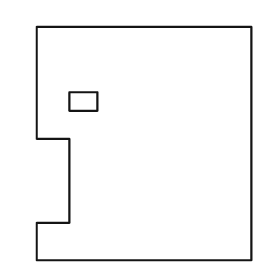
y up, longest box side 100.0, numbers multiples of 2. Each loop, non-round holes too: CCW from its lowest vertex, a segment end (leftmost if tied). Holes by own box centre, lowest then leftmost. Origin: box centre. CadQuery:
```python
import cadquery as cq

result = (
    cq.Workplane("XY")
    .moveTo(-46.0, -50.0)
    .lineTo(46.0, -50.0)
    .lineTo(46.0, 50.0)
    .lineTo(-46.0, 50.0)
    .lineTo(-46.0, 2.0)
    .lineTo(-32.0, 2.0)
    .lineTo(-32.0, -34.0)
    .lineTo(-46.0, -34.0)
    .close()
    .moveTo(-32.0, 14.0)
    .lineTo(-20.0, 14.0)
    .lineTo(-20.0, 22.0)
    .lineTo(-32.0, 22.0)
    .close()
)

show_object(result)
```